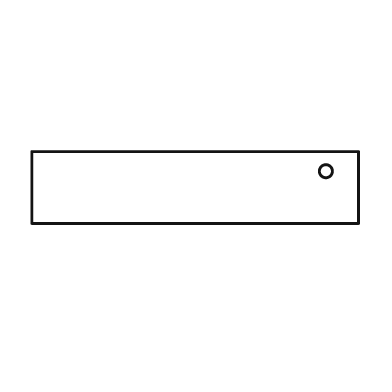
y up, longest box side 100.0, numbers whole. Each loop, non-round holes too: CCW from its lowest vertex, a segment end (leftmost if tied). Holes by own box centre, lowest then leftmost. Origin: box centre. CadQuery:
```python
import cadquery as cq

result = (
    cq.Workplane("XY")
    .moveTo(-50.0, -11.0)
    .lineTo(50.0, -11.0)
    .lineTo(50.0, 11.0)
    .lineTo(-50.0, 11.0)
    .close()
    .moveTo(40.0, 5.0)
    .circle(2.0)
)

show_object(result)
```